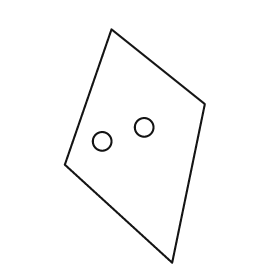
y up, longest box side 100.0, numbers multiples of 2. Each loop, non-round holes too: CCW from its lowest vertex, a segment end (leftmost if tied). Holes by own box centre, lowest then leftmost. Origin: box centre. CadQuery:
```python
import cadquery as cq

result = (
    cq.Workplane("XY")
    .moveTo(16.0, -50.0)
    .lineTo(30.0, 18.0)
    .lineTo(-10.0, 50.0)
    .lineTo(-30.0, -8.0)
    .close()
    .moveTo(-14.0, 2.0)
    .circle(4.0)
    .moveTo(4.0, 8.0)
    .circle(4.0)
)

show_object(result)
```